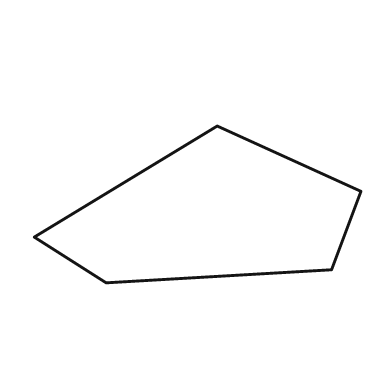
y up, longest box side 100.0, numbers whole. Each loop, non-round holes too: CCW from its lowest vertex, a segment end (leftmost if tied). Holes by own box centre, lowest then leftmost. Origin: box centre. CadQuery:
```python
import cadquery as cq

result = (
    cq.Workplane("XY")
    .moveTo(-28.0, -24.0)
    .lineTo(41.0, -20.0)
    .lineTo(50.0, 4.0)
    .lineTo(6.0, 24.0)
    .lineTo(-50.0, -10.0)
    .close()
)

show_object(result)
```